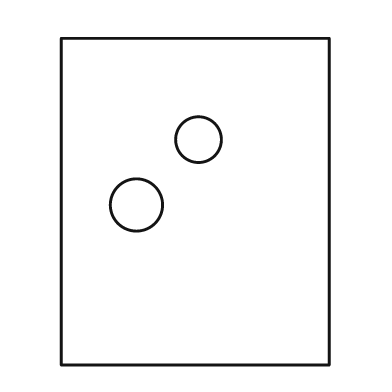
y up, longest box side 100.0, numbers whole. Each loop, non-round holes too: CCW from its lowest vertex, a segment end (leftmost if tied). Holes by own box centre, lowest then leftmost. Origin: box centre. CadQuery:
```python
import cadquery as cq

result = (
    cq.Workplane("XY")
    .moveTo(-41.0, -50.0)
    .lineTo(41.0, -50.0)
    .lineTo(41.0, 50.0)
    .lineTo(-41.0, 50.0)
    .close()
    .moveTo(-18.0, -1.0)
    .circle(8.0)
    .moveTo(1.0, 19.0)
    .circle(7.0)
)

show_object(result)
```